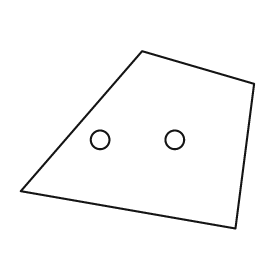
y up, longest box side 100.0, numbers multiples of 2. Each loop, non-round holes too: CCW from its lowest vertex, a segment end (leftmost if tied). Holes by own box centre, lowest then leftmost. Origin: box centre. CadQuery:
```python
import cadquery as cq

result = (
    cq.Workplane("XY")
    .moveTo(42.0, -38.0)
    .lineTo(50.0, 24.0)
    .lineTo(2.0, 38.0)
    .lineTo(-50.0, -22.0)
    .close()
    .moveTo(-16.0, 0.0)
    .circle(4.0)
    .moveTo(16.0, 0.0)
    .circle(4.0)
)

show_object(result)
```